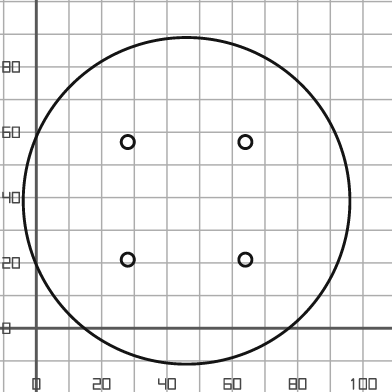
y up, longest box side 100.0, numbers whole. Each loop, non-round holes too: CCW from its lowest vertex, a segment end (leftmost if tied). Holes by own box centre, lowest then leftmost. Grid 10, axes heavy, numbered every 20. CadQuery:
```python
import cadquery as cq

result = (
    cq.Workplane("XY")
    .moveTo(46.0, 39.0)
    .circle(50.0)
    .moveTo(28.0, 21.0)
    .circle(2.0)
    .moveTo(64.0, 21.0)
    .circle(2.0)
    .moveTo(28.0, 57.0)
    .circle(2.0)
    .moveTo(64.0, 57.0)
    .circle(2.0)
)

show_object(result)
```